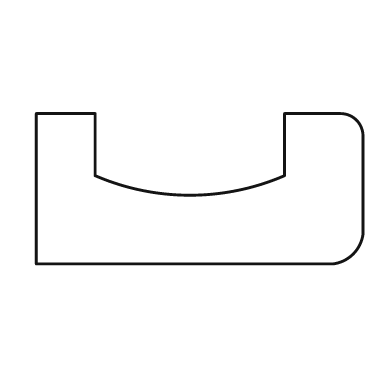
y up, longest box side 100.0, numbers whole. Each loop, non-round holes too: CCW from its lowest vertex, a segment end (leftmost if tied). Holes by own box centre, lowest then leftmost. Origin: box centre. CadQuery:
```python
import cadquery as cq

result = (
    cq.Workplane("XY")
    .moveTo(-50.0, -23.0)
    .lineTo(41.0, -23.0)
    .threePointArc((47.0, -20.0), (50.0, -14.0))
    .lineTo(50.0, 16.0)
    .threePointArc((48.0, 21.0), (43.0, 23.0))
    .lineTo(26.0, 23.0)
    .lineTo(26.0, 4.0)
    .threePointArc((-3.0, -2.0), (-32.0, 4.0))
    .lineTo(-32.0, 23.0)
    .lineTo(-50.0, 23.0)
    .close()
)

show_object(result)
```